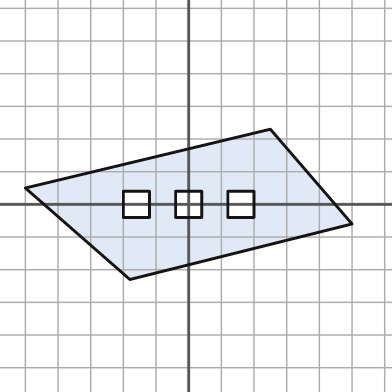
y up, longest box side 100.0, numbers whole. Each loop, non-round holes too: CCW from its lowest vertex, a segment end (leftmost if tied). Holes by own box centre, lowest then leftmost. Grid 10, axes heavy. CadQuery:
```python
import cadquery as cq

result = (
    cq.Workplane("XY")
    .moveTo(-18.0, -23.0)
    .lineTo(50.0, -6.0)
    .lineTo(25.0, 23.0)
    .lineTo(-50.0, 5.0)
    .close()
    .moveTo(-20.0, -4.0)
    .lineTo(-12.0, -4.0)
    .lineTo(-12.0, 4.0)
    .lineTo(-20.0, 4.0)
    .close()
    .moveTo(-4.0, -4.0)
    .lineTo(4.0, -4.0)
    .lineTo(4.0, 4.0)
    .lineTo(-4.0, 4.0)
    .close()
    .moveTo(12.0, -4.0)
    .lineTo(20.0, -4.0)
    .lineTo(20.0, 4.0)
    .lineTo(12.0, 4.0)
    .close()
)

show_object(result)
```